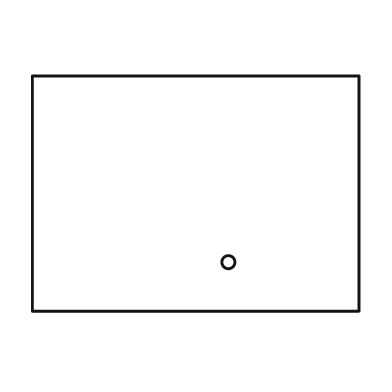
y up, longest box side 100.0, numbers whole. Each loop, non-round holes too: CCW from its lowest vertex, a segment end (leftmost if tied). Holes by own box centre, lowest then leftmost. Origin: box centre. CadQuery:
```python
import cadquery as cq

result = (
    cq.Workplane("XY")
    .moveTo(-50.0, -36.0)
    .lineTo(50.0, -36.0)
    .lineTo(50.0, 36.0)
    .lineTo(-50.0, 36.0)
    .close()
    .moveTo(10.0, -21.0)
    .circle(2.0)
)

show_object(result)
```